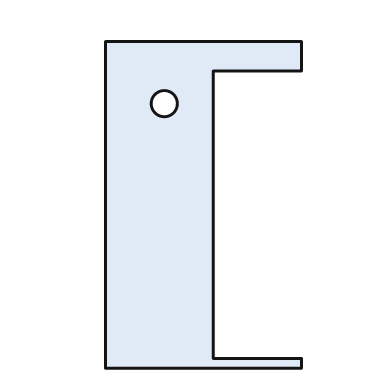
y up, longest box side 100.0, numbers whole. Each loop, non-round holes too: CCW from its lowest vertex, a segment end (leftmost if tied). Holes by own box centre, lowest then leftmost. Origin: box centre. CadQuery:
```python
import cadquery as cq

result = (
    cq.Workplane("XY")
    .moveTo(-30.0, -50.0)
    .lineTo(30.0, -50.0)
    .lineTo(30.0, -47.0)
    .lineTo(3.0, -47.0)
    .lineTo(3.0, 41.0)
    .lineTo(30.0, 41.0)
    .lineTo(30.0, 50.0)
    .lineTo(-30.0, 50.0)
    .close()
    .moveTo(-12.0, 31.0)
    .circle(4.0)
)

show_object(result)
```